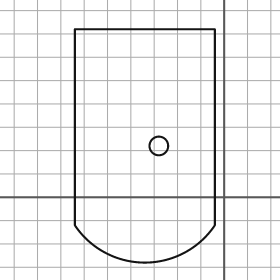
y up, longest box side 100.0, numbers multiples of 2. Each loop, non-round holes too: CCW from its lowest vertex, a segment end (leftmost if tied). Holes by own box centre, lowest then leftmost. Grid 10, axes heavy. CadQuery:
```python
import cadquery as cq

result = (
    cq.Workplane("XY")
    .moveTo(-64.0, -12.0)
    .threePointArc((-34.0, -28.0), (-4.0, -12.0))
    .lineTo(-4.0, 72.0)
    .lineTo(-64.0, 72.0)
    .close()
    .moveTo(-28.0, 22.0)
    .circle(4.0)
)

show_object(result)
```